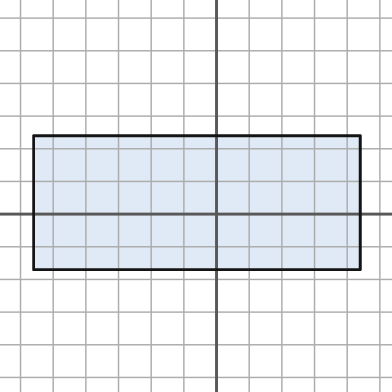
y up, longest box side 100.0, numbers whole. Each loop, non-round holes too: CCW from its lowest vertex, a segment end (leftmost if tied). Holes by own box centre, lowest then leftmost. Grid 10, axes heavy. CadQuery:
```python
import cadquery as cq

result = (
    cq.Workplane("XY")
    .moveTo(-56.0, -17.0)
    .lineTo(44.0, -17.0)
    .lineTo(44.0, 24.0)
    .lineTo(-56.0, 24.0)
    .close()
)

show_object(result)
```